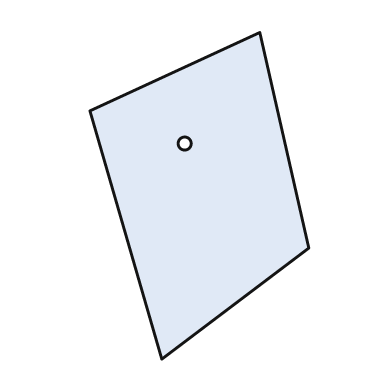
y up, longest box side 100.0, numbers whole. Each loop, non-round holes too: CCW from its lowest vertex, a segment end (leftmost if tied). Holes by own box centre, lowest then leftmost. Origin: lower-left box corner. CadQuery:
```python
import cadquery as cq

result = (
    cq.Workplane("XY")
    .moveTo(22.0, 0.0)
    .lineTo(67.0, 34.0)
    .lineTo(52.0, 100.0)
    .lineTo(0.0, 76.0)
    .close()
    .moveTo(29.0, 66.0)
    .circle(2.0)
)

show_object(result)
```